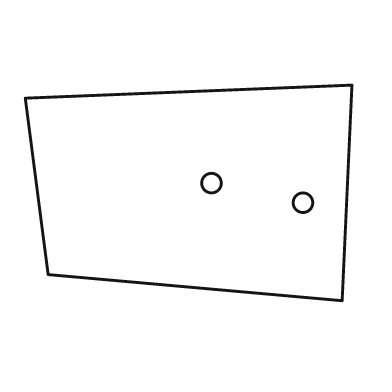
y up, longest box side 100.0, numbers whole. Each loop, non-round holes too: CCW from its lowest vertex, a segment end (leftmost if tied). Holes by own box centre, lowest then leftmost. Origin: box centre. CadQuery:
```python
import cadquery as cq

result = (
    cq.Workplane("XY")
    .moveTo(47.0, -33.0)
    .lineTo(50.0, 33.0)
    .lineTo(-50.0, 29.0)
    .lineTo(-43.0, -25.0)
    .close()
    .moveTo(35.0, -3.0)
    .circle(3.0)
    .moveTo(7.0, 3.0)
    .circle(3.0)
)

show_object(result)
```